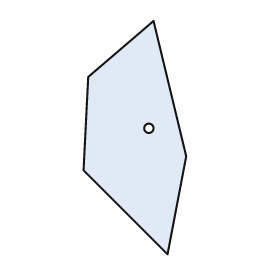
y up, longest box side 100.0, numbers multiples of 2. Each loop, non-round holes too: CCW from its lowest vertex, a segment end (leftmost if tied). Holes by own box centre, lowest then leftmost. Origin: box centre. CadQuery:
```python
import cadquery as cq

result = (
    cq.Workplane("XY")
    .moveTo(14.0, -50.0)
    .lineTo(22.0, -8.0)
    .lineTo(8.0, 50.0)
    .lineTo(-20.0, 26.0)
    .lineTo(-22.0, -14.0)
    .close()
    .moveTo(6.0, 4.0)
    .circle(2.0)
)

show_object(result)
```